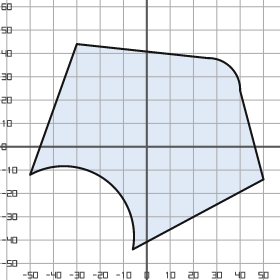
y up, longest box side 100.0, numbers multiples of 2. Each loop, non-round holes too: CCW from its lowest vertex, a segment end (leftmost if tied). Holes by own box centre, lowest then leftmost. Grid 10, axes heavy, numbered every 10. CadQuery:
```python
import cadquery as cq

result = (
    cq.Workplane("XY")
    .moveTo(-6.0, -44.0)
    .lineTo(50.0, -14.0)
    .lineTo(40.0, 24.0)
    .threePointArc((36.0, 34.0), (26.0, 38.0))
    .lineTo(-30.0, 44.0)
    .lineTo(-50.0, -12.0)
    .threePointArc((-18.0, -14.0), (-6.0, -44.0))
    .close()
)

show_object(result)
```